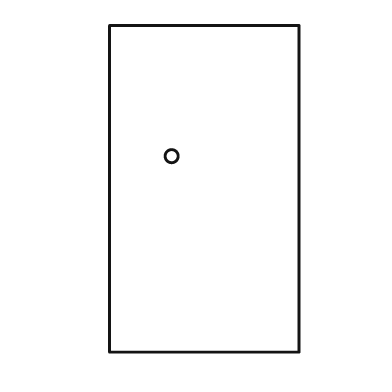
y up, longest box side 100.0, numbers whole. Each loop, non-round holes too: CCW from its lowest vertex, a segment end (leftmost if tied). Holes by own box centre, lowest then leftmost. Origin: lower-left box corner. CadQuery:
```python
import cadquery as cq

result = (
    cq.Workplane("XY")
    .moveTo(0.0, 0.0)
    .lineTo(58.0, 0.0)
    .lineTo(58.0, 100.0)
    .lineTo(0.0, 100.0)
    .close()
    .moveTo(19.0, 60.0)
    .circle(2.0)
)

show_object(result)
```